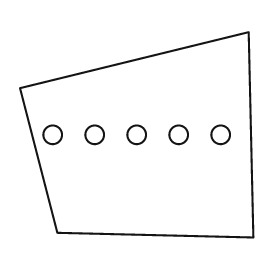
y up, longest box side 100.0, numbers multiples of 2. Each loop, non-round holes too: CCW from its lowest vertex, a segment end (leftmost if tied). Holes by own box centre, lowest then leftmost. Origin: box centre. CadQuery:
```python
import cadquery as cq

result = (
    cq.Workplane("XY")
    .moveTo(50.0, -44.0)
    .lineTo(48.0, 44.0)
    .lineTo(-50.0, 20.0)
    .lineTo(-34.0, -42.0)
    .close()
    .moveTo(-36.0, 0.0)
    .circle(4.0)
    .moveTo(-18.0, 0.0)
    .circle(4.0)
    .moveTo(0.0, 0.0)
    .circle(4.0)
    .moveTo(18.0, 0.0)
    .circle(4.0)
    .moveTo(36.0, 0.0)
    .circle(4.0)
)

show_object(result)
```